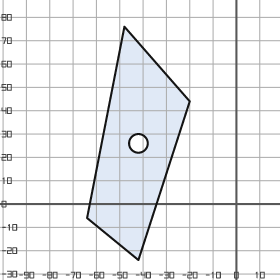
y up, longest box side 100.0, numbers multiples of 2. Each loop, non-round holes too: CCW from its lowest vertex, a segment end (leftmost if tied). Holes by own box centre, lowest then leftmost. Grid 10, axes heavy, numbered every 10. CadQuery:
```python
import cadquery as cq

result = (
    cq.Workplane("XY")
    .moveTo(-42.0, -24.0)
    .lineTo(-20.0, 44.0)
    .lineTo(-48.0, 76.0)
    .lineTo(-64.0, -6.0)
    .close()
    .moveTo(-42.0, 26.0)
    .circle(4.0)
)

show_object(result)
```